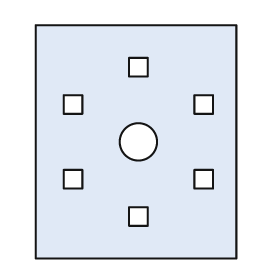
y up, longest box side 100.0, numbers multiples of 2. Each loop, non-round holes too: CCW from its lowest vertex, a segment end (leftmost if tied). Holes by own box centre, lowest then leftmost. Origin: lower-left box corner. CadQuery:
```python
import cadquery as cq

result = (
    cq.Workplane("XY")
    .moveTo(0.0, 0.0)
    .lineTo(86.0, 0.0)
    .lineTo(86.0, 100.0)
    .lineTo(0.0, 100.0)
    .close()
    .moveTo(40.0, 14.0)
    .lineTo(48.0, 14.0)
    .lineTo(48.0, 22.0)
    .lineTo(40.0, 22.0)
    .close()
    .moveTo(12.0, 30.0)
    .lineTo(20.0, 30.0)
    .lineTo(20.0, 38.0)
    .lineTo(12.0, 38.0)
    .close()
    .moveTo(68.0, 30.0)
    .lineTo(76.0, 30.0)
    .lineTo(76.0, 38.0)
    .lineTo(68.0, 38.0)
    .close()
    .moveTo(44.0, 50.0)
    .circle(8.0)
    .moveTo(12.0, 62.0)
    .lineTo(20.0, 62.0)
    .lineTo(20.0, 70.0)
    .lineTo(12.0, 70.0)
    .close()
    .moveTo(68.0, 62.0)
    .lineTo(76.0, 62.0)
    .lineTo(76.0, 70.0)
    .lineTo(68.0, 70.0)
    .close()
    .moveTo(40.0, 78.0)
    .lineTo(48.0, 78.0)
    .lineTo(48.0, 86.0)
    .lineTo(40.0, 86.0)
    .close()
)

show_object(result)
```